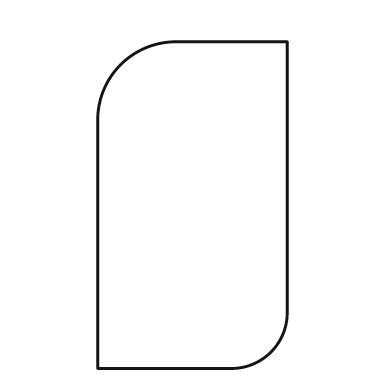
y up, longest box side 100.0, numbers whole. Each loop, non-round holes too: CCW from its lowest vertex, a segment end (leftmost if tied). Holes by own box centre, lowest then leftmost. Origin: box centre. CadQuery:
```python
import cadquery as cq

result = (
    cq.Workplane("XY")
    .moveTo(-29.0, -50.0)
    .lineTo(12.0, -50.0)
    .threePointArc((24.0, -45.0), (29.0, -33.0))
    .lineTo(29.0, 50.0)
    .lineTo(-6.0, 50.0)
    .threePointArc((-22.0, 43.0), (-29.0, 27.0))
    .close()
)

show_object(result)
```